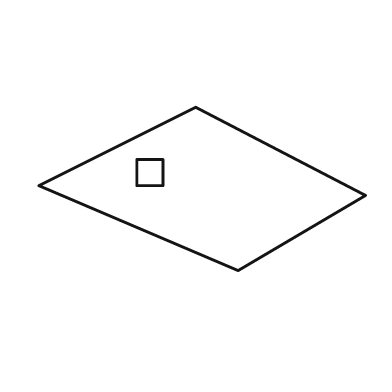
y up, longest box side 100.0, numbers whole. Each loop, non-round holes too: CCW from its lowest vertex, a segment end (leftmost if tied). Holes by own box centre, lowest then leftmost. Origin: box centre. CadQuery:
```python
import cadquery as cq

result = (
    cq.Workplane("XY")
    .moveTo(11.0, -25.0)
    .lineTo(50.0, -2.0)
    .lineTo(-2.0, 25.0)
    .lineTo(-50.0, 1.0)
    .close()
    .moveTo(-20.0, 1.0)
    .lineTo(-12.0, 1.0)
    .lineTo(-12.0, 9.0)
    .lineTo(-20.0, 9.0)
    .close()
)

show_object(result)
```